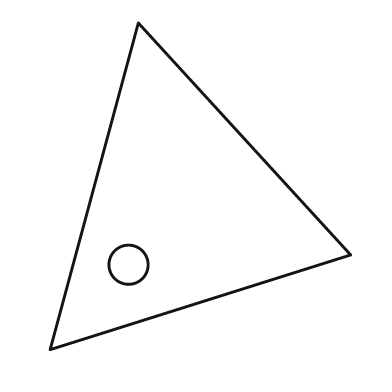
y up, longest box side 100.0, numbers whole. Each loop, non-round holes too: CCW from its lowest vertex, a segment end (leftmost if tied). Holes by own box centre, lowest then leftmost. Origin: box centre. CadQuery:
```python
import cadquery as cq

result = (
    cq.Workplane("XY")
    .moveTo(-46.0, -50.0)
    .lineTo(46.0, -21.0)
    .lineTo(-19.0, 50.0)
    .close()
    .moveTo(-22.0, -24.0)
    .circle(6.0)
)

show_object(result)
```